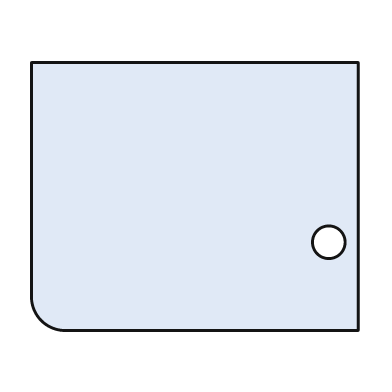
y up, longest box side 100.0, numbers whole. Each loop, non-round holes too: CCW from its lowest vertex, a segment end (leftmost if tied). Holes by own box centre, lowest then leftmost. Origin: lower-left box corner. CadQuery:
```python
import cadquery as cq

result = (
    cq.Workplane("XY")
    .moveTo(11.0, 0.0)
    .lineTo(100.0, 0.0)
    .lineTo(100.0, 82.0)
    .lineTo(0.0, 82.0)
    .lineTo(0.0, 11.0)
    .threePointArc((3.0, 3.0), (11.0, 0.0))
    .close()
    .moveTo(91.0, 27.0)
    .circle(5.0)
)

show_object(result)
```